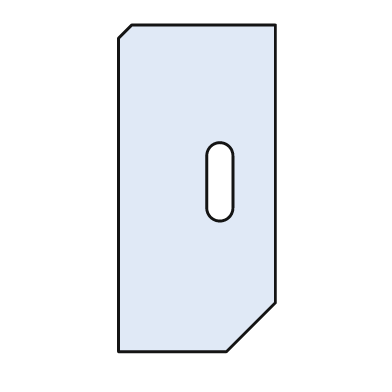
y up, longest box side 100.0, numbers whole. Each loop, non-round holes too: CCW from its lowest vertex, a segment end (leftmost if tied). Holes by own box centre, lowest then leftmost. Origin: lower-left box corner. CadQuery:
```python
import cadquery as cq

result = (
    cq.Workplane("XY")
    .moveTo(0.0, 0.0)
    .lineTo(33.0, 0.0)
    .lineTo(48.0, 15.0)
    .lineTo(48.0, 100.0)
    .lineTo(4.0, 100.0)
    .lineTo(0.0, 96.0)
    .close()
    .moveTo(27.0, 44.0)
    .threePointArc((31.0, 40.0), (35.0, 44.0))
    .lineTo(35.0, 60.0)
    .threePointArc((31.0, 64.0), (27.0, 60.0))
    .close()
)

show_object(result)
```